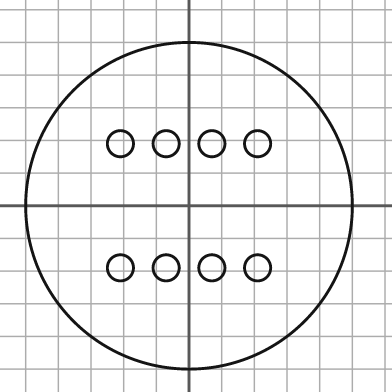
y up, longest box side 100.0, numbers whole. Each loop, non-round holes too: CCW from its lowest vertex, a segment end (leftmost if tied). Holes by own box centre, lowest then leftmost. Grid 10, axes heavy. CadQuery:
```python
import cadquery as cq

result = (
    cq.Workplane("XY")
    .moveTo(0.0, 0.0)
    .circle(50.0)
    .moveTo(-21.0, -19.0)
    .circle(4.0)
    .moveTo(-7.0, -19.0)
    .circle(4.0)
    .moveTo(7.0, -19.0)
    .circle(4.0)
    .moveTo(21.0, -19.0)
    .circle(4.0)
    .moveTo(-21.0, 19.0)
    .circle(4.0)
    .moveTo(-7.0, 19.0)
    .circle(4.0)
    .moveTo(7.0, 19.0)
    .circle(4.0)
    .moveTo(21.0, 19.0)
    .circle(4.0)
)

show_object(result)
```